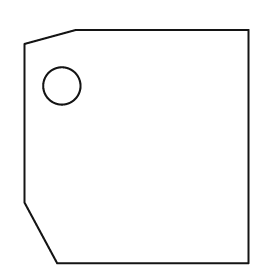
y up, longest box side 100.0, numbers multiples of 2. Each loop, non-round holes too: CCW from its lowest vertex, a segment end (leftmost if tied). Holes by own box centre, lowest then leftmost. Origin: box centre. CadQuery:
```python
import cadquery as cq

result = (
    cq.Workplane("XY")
    .moveTo(-34.0, -50.0)
    .lineTo(48.0, -50.0)
    .lineTo(48.0, 50.0)
    .lineTo(-26.0, 50.0)
    .lineTo(-48.0, 44.0)
    .lineTo(-48.0, -24.0)
    .close()
    .moveTo(-32.0, 26.0)
    .circle(8.0)
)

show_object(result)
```